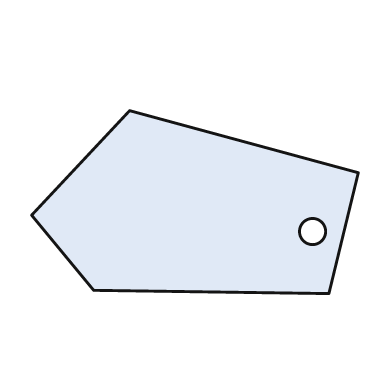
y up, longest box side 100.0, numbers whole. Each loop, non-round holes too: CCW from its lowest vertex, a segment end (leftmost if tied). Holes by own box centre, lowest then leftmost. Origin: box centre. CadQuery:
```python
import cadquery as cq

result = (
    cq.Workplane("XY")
    .moveTo(41.0, -28.0)
    .lineTo(50.0, 9.0)
    .lineTo(-20.0, 28.0)
    .lineTo(-50.0, -4.0)
    .lineTo(-31.0, -27.0)
    .close()
    .moveTo(36.0, -9.0)
    .circle(4.0)
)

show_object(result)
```